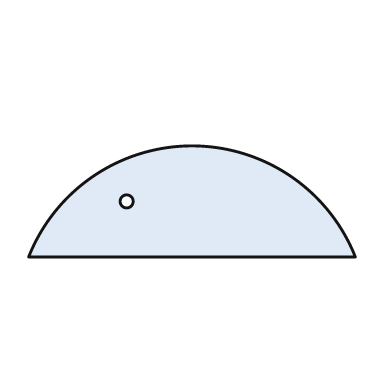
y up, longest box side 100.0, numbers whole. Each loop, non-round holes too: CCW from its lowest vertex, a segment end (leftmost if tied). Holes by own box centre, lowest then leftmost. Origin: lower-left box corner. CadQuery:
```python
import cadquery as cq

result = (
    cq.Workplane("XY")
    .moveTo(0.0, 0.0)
    .lineTo(100.0, 0.0)
    .threePointArc((50.0, 34.0), (0.0, 0.0))
    .close()
    .moveTo(30.0, 17.0)
    .circle(2.0)
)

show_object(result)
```